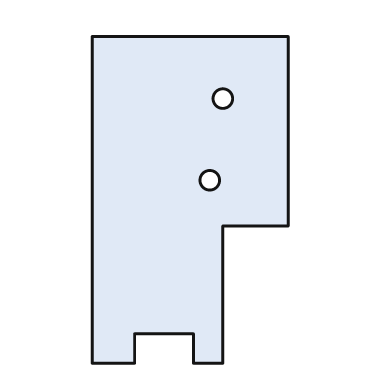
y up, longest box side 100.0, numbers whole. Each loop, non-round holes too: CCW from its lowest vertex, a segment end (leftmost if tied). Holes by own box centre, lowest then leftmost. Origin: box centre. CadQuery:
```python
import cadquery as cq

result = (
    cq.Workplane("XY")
    .moveTo(-30.0, -50.0)
    .lineTo(-17.0, -50.0)
    .lineTo(-17.0, -41.0)
    .lineTo(1.0, -41.0)
    .lineTo(1.0, -50.0)
    .lineTo(10.0, -50.0)
    .lineTo(10.0, -8.0)
    .lineTo(30.0, -8.0)
    .lineTo(30.0, 50.0)
    .lineTo(-30.0, 50.0)
    .close()
    .moveTo(6.0, 6.0)
    .circle(3.0)
    .moveTo(10.0, 31.0)
    .circle(3.0)
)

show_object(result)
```